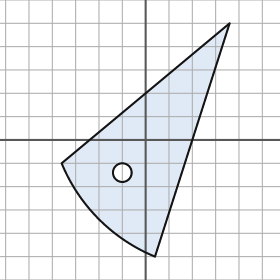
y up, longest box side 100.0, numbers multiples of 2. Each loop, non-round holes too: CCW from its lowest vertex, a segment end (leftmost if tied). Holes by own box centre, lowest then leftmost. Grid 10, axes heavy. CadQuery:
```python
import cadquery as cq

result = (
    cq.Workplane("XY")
    .moveTo(4.0, -50.0)
    .lineTo(36.0, 50.0)
    .lineTo(-36.0, -10.0)
    .threePointArc((-20.0, -34.0), (4.0, -50.0))
    .close()
    .moveTo(-10.0, -14.0)
    .circle(4.0)
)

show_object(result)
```